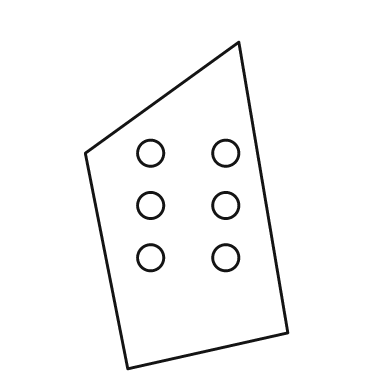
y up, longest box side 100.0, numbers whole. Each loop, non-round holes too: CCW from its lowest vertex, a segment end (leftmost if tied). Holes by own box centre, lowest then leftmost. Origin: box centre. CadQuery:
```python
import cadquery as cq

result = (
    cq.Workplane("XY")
    .moveTo(-18.0, -50.0)
    .lineTo(31.0, -39.0)
    .lineTo(16.0, 50.0)
    .lineTo(-31.0, 16.0)
    .close()
    .moveTo(-11.0, -16.0)
    .circle(4.0)
    .moveTo(12.0, -16.0)
    .circle(4.0)
    .moveTo(-11.0, 0.0)
    .circle(4.0)
    .moveTo(12.0, 0.0)
    .circle(4.0)
    .moveTo(-11.0, 16.0)
    .circle(4.0)
    .moveTo(12.0, 16.0)
    .circle(4.0)
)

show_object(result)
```